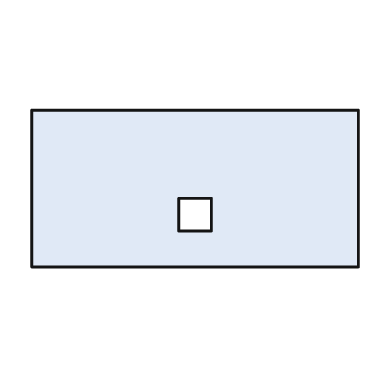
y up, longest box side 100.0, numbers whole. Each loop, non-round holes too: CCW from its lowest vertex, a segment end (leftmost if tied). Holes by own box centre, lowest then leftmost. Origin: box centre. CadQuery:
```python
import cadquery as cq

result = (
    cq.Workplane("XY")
    .moveTo(-50.0, -24.0)
    .lineTo(50.0, -24.0)
    .lineTo(50.0, 24.0)
    .lineTo(-50.0, 24.0)
    .close()
    .moveTo(-5.0, -13.0)
    .lineTo(5.0, -13.0)
    .lineTo(5.0, -3.0)
    .lineTo(-5.0, -3.0)
    .close()
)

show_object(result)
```